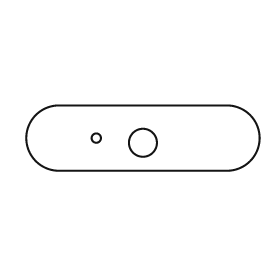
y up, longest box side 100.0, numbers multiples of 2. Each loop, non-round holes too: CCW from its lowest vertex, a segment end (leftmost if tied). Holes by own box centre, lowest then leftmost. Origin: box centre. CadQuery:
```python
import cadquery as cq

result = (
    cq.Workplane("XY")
    .moveTo(-36.0, -14.0)
    .lineTo(36.0, -14.0)
    .threePointArc((50.0, 0.0), (36.0, 14.0))
    .lineTo(-36.0, 14.0)
    .threePointArc((-50.0, 0.0), (-36.0, -14.0))
    .close()
    .moveTo(0.0, -2.0)
    .circle(6.0)
    .moveTo(-20.0, 0.0)
    .circle(2.0)
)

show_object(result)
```